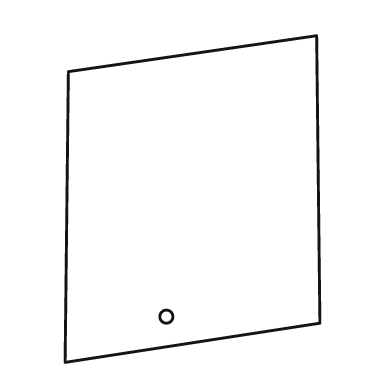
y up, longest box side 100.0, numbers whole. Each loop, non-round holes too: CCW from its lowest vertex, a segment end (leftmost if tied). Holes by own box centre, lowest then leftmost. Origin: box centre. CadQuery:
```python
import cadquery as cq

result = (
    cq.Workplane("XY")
    .moveTo(-39.0, -50.0)
    .lineTo(39.0, -38.0)
    .lineTo(38.0, 50.0)
    .lineTo(-38.0, 39.0)
    .close()
    .moveTo(-8.0, -36.0)
    .circle(2.0)
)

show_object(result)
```